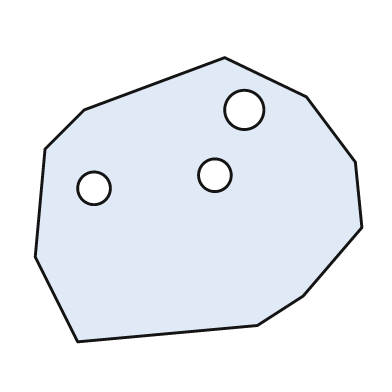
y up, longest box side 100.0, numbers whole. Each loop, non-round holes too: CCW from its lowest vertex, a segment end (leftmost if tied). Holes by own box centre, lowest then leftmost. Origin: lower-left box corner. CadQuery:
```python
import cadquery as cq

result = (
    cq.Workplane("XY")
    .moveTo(13.0, 0.0)
    .lineTo(68.0, 5.0)
    .lineTo(82.0, 14.0)
    .lineTo(100.0, 35.0)
    .lineTo(98.0, 55.0)
    .lineTo(83.0, 75.0)
    .lineTo(58.0, 87.0)
    .lineTo(15.0, 71.0)
    .lineTo(3.0, 59.0)
    .lineTo(0.0, 26.0)
    .close()
    .moveTo(18.0, 47.0)
    .circle(5.0)
    .moveTo(55.0, 51.0)
    .circle(5.0)
    .moveTo(64.0, 71.0)
    .circle(6.0)
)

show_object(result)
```